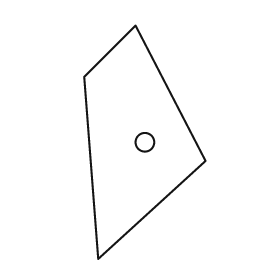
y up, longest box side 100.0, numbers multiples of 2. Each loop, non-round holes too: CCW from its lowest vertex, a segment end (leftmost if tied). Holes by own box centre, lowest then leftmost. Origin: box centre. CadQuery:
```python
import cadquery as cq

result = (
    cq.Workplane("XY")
    .moveTo(-20.0, -50.0)
    .lineTo(26.0, -8.0)
    .lineTo(-4.0, 50.0)
    .lineTo(-26.0, 28.0)
    .close()
    .moveTo(0.0, 0.0)
    .circle(4.0)
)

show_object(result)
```